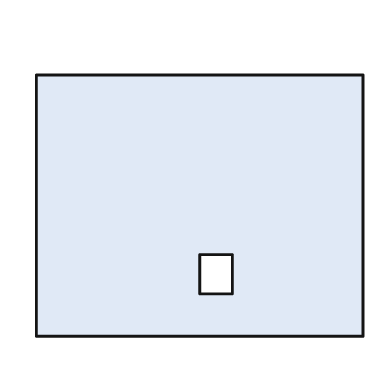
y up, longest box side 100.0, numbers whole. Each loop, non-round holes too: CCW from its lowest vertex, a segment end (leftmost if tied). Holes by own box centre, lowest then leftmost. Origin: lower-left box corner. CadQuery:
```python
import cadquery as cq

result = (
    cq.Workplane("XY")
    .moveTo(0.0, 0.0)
    .lineTo(100.0, 0.0)
    .lineTo(100.0, 80.0)
    .lineTo(0.0, 80.0)
    .close()
    .moveTo(50.0, 13.0)
    .lineTo(60.0, 13.0)
    .lineTo(60.0, 25.0)
    .lineTo(50.0, 25.0)
    .close()
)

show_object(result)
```